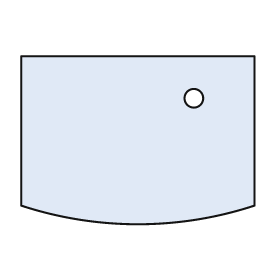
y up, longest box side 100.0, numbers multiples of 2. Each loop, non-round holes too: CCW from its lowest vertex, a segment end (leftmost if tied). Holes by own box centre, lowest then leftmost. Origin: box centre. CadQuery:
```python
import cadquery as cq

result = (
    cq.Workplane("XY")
    .moveTo(-50.0, -28.0)
    .threePointArc((0.0, -36.0), (50.0, -28.0))
    .lineTo(50.0, 36.0)
    .lineTo(-50.0, 36.0)
    .close()
    .moveTo(24.0, 18.0)
    .circle(4.0)
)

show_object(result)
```